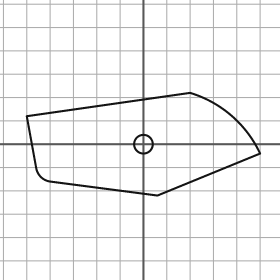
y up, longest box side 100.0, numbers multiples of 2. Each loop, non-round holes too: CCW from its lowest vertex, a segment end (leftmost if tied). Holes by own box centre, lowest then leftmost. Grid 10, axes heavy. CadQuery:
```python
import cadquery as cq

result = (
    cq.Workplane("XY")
    .moveTo(6.0, -22.0)
    .lineTo(50.0, -4.0)
    .threePointArc((38.0, 12.0), (20.0, 22.0))
    .lineTo(-50.0, 12.0)
    .lineTo(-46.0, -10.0)
    .threePointArc((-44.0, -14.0), (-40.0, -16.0))
    .close()
    .moveTo(0.0, 0.0)
    .circle(4.0)
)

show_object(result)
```